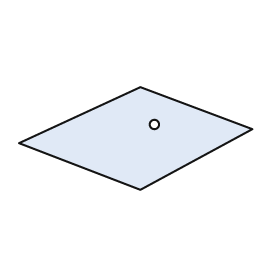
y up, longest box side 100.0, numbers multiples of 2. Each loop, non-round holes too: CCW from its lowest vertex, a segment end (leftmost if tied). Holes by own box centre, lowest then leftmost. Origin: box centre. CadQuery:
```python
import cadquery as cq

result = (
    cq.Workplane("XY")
    .moveTo(2.0, -22.0)
    .lineTo(50.0, 4.0)
    .lineTo(2.0, 22.0)
    .lineTo(-50.0, -2.0)
    .close()
    .moveTo(8.0, 6.0)
    .circle(2.0)
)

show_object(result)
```